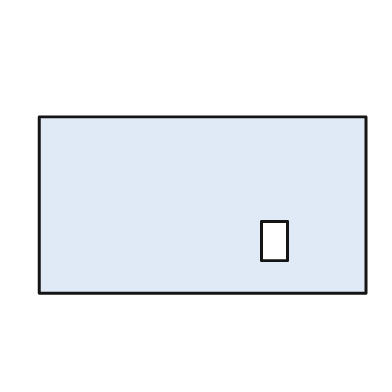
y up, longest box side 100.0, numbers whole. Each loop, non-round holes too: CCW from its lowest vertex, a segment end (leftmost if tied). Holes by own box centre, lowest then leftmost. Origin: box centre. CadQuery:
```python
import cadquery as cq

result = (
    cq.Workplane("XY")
    .moveTo(-50.0, -27.0)
    .lineTo(50.0, -27.0)
    .lineTo(50.0, 27.0)
    .lineTo(-50.0, 27.0)
    .close()
    .moveTo(18.0, -17.0)
    .lineTo(26.0, -17.0)
    .lineTo(26.0, -5.0)
    .lineTo(18.0, -5.0)
    .close()
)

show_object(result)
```